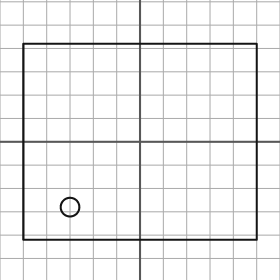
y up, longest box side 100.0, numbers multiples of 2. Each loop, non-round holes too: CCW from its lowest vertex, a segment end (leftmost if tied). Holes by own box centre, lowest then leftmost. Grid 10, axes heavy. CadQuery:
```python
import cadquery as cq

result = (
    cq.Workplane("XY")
    .moveTo(-50.0, -42.0)
    .lineTo(50.0, -42.0)
    .lineTo(50.0, 42.0)
    .lineTo(-50.0, 42.0)
    .close()
    .moveTo(-30.0, -28.0)
    .circle(4.0)
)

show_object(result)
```